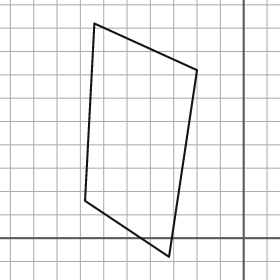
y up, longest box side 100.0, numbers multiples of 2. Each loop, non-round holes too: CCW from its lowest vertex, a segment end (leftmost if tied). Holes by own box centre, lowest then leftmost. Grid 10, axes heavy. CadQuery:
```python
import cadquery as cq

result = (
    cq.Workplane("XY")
    .moveTo(-32.0, -8.0)
    .lineTo(-20.0, 72.0)
    .lineTo(-64.0, 92.0)
    .lineTo(-68.0, 16.0)
    .close()
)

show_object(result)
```